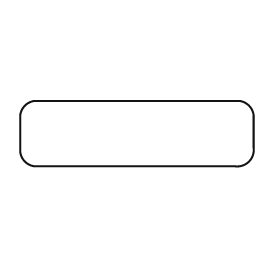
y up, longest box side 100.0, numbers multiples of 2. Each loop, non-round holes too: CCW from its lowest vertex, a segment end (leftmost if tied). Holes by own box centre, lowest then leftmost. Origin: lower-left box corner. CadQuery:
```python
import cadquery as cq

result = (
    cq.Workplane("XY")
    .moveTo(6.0, 0.0)
    .lineTo(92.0, 0.0)
    .threePointArc((98.0, 2.0), (100.0, 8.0))
    .lineTo(100.0, 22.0)
    .threePointArc((98.0, 26.0), (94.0, 28.0))
    .lineTo(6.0, 28.0)
    .threePointArc((2.0, 26.0), (0.0, 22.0))
    .lineTo(0.0, 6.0)
    .threePointArc((2.0, 2.0), (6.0, 0.0))
    .close()
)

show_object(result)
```